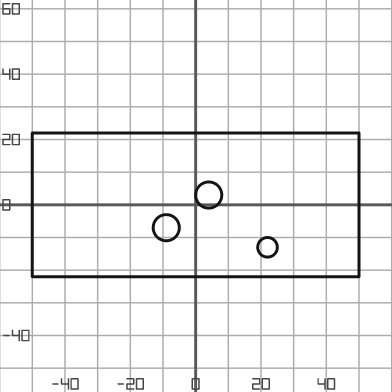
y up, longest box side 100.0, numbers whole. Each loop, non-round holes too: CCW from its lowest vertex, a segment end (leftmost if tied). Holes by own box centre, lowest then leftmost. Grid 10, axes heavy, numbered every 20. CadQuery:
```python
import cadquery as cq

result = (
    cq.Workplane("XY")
    .moveTo(-50.0, -22.0)
    .lineTo(50.0, -22.0)
    .lineTo(50.0, 22.0)
    .lineTo(-50.0, 22.0)
    .close()
    .moveTo(22.0, -13.0)
    .circle(3.0)
    .moveTo(-9.0, -7.0)
    .circle(4.0)
    .moveTo(4.0, 3.0)
    .circle(4.0)
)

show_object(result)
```